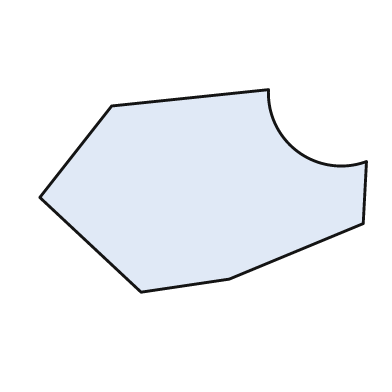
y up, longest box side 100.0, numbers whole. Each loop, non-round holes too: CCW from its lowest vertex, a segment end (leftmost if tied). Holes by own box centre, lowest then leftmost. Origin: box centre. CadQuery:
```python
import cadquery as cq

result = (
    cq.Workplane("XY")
    .moveTo(-19.0, -31.0)
    .lineTo(8.0, -27.0)
    .lineTo(49.0, -10.0)
    .lineTo(50.0, 9.0)
    .threePointArc((29.0, 12.0), (20.0, 31.0))
    .lineTo(-28.0, 26.0)
    .lineTo(-50.0, -2.0)
    .close()
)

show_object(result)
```